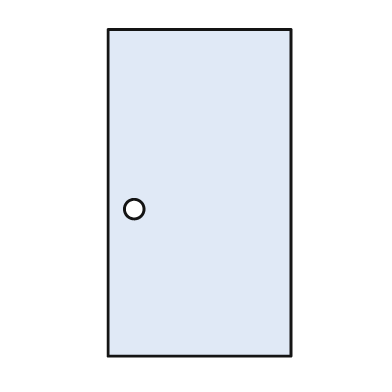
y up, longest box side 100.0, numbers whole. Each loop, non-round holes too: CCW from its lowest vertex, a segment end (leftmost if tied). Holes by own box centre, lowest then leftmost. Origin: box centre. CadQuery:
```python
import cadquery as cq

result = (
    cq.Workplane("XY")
    .moveTo(-28.0, -50.0)
    .lineTo(28.0, -50.0)
    .lineTo(28.0, 50.0)
    .lineTo(-28.0, 50.0)
    .close()
    .moveTo(-20.0, -5.0)
    .circle(3.0)
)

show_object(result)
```